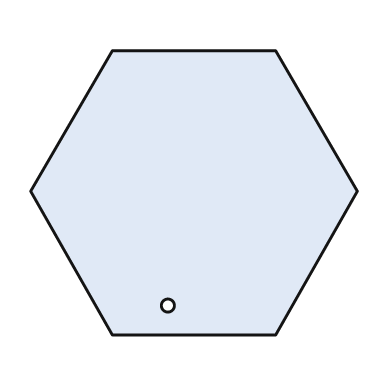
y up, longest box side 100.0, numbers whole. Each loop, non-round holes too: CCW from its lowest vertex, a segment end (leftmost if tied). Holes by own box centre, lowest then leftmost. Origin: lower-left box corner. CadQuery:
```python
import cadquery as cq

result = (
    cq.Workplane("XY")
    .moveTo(25.0, 0.0)
    .lineTo(75.0, 0.0)
    .lineTo(100.0, 44.0)
    .lineTo(75.0, 87.0)
    .lineTo(25.0, 87.0)
    .lineTo(0.0, 44.0)
    .close()
    .moveTo(42.0, 9.0)
    .circle(2.0)
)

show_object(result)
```